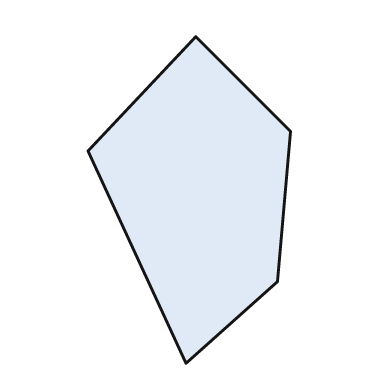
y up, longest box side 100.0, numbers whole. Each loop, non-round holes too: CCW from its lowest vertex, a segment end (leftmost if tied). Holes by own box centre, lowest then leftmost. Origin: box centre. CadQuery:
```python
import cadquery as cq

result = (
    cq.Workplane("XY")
    .moveTo(-1.0, -50.0)
    .lineTo(27.0, -25.0)
    .lineTo(31.0, 21.0)
    .lineTo(2.0, 50.0)
    .lineTo(-31.0, 15.0)
    .close()
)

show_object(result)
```